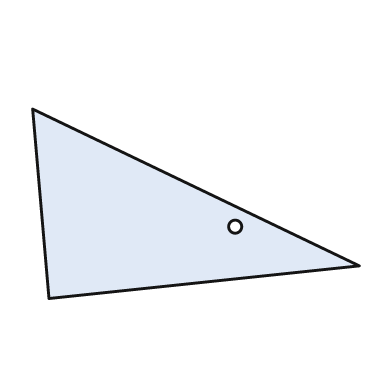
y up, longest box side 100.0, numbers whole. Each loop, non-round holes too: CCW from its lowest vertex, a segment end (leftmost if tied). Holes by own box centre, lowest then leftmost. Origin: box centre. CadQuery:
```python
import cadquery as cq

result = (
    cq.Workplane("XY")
    .moveTo(-45.0, -29.0)
    .lineTo(50.0, -19.0)
    .lineTo(-50.0, 29.0)
    .close()
    .moveTo(12.0, -7.0)
    .circle(2.0)
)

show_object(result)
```